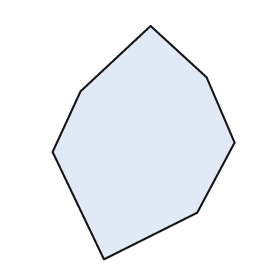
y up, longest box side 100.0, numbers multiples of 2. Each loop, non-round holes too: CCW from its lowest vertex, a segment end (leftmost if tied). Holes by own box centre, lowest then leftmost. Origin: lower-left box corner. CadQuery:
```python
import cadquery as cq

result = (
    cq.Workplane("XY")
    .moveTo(22.0, 0.0)
    .lineTo(62.0, 20.0)
    .lineTo(78.0, 50.0)
    .lineTo(66.0, 78.0)
    .lineTo(42.0, 100.0)
    .lineTo(12.0, 72.0)
    .lineTo(0.0, 46.0)
    .close()
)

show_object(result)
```